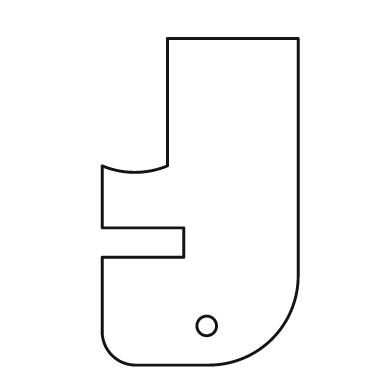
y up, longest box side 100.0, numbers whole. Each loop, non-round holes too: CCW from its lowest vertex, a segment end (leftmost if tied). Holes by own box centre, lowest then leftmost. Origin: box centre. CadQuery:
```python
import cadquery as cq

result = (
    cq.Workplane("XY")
    .moveTo(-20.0, -50.0)
    .lineTo(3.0, -50.0)
    .threePointArc((22.0, -42.0), (30.0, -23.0))
    .lineTo(30.0, 50.0)
    .lineTo(-10.0, 50.0)
    .lineTo(-10.0, 11.0)
    .threePointArc((-20.0, 9.0), (-30.0, 11.0))
    .lineTo(-30.0, -8.0)
    .lineTo(-5.0, -8.0)
    .lineTo(-5.0, -17.0)
    .lineTo(-30.0, -17.0)
    .lineTo(-30.0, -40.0)
    .threePointArc((-27.0, -47.0), (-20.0, -50.0))
    .close()
    .moveTo(2.0, -38.0)
    .circle(3.0)
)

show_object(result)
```